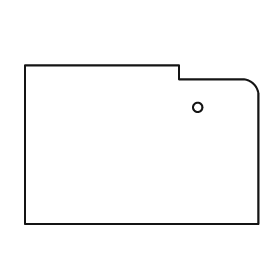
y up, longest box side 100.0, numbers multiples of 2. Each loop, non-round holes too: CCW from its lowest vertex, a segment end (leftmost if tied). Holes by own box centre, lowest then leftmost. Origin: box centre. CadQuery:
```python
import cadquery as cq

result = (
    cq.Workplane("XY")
    .moveTo(-50.0, -34.0)
    .lineTo(50.0, -34.0)
    .lineTo(50.0, 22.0)
    .threePointArc((48.0, 26.0), (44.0, 28.0))
    .lineTo(16.0, 28.0)
    .lineTo(16.0, 34.0)
    .lineTo(-50.0, 34.0)
    .close()
    .moveTo(24.0, 16.0)
    .circle(2.0)
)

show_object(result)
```